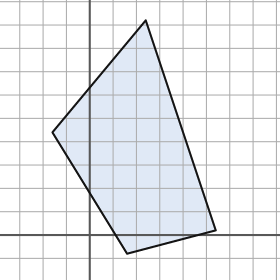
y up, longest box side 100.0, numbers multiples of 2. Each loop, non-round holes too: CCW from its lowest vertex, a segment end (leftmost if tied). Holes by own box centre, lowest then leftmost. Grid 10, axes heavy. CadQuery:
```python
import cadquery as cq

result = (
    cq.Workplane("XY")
    .moveTo(16.0, -8.0)
    .lineTo(54.0, 2.0)
    .lineTo(24.0, 92.0)
    .lineTo(-16.0, 44.0)
    .close()
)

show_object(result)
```